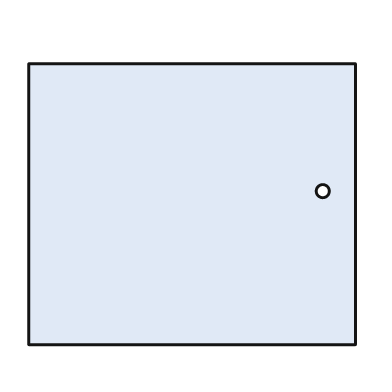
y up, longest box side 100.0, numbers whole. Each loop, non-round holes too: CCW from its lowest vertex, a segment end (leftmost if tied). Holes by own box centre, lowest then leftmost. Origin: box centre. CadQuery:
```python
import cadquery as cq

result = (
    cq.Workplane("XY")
    .moveTo(-50.0, -43.0)
    .lineTo(50.0, -43.0)
    .lineTo(50.0, 43.0)
    .lineTo(-50.0, 43.0)
    .close()
    .moveTo(40.0, 4.0)
    .circle(2.0)
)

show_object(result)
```